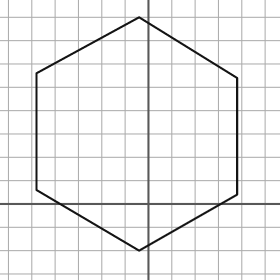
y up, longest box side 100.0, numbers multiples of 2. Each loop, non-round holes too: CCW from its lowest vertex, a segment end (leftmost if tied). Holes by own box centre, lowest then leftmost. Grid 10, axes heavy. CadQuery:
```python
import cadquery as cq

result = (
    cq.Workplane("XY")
    .moveTo(-4.0, -20.0)
    .lineTo(38.0, 4.0)
    .lineTo(38.0, 54.0)
    .lineTo(-4.0, 80.0)
    .lineTo(-48.0, 56.0)
    .lineTo(-48.0, 6.0)
    .close()
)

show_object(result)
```